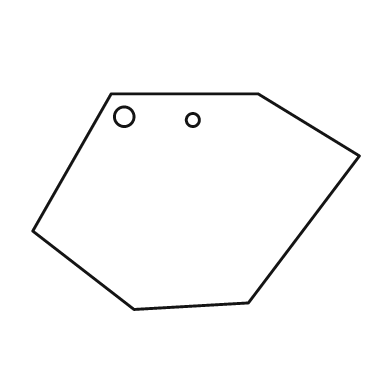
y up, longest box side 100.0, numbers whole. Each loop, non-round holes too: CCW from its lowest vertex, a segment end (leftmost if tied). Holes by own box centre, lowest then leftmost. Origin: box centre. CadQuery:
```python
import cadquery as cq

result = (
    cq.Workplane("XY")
    .moveTo(-19.0, -33.0)
    .lineTo(16.0, -31.0)
    .lineTo(50.0, 14.0)
    .lineTo(19.0, 33.0)
    .lineTo(-26.0, 33.0)
    .lineTo(-50.0, -9.0)
    .close()
    .moveTo(-1.0, 25.0)
    .circle(2.0)
    .moveTo(-22.0, 26.0)
    .circle(3.0)
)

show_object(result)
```